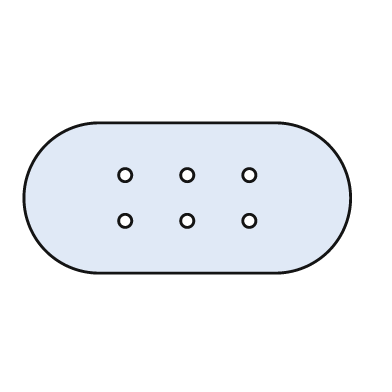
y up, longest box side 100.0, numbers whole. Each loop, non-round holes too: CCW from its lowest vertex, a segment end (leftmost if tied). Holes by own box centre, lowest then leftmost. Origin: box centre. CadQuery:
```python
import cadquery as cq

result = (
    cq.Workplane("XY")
    .moveTo(-27.0, -23.0)
    .lineTo(27.0, -23.0)
    .threePointArc((50.0, 0.0), (27.0, 23.0))
    .lineTo(-27.0, 23.0)
    .threePointArc((-50.0, 0.0), (-27.0, -23.0))
    .close()
    .moveTo(-19.0, -7.0)
    .circle(2.0)
    .moveTo(0.0, -7.0)
    .circle(2.0)
    .moveTo(19.0, -7.0)
    .circle(2.0)
    .moveTo(-19.0, 7.0)
    .circle(2.0)
    .moveTo(0.0, 7.0)
    .circle(2.0)
    .moveTo(19.0, 7.0)
    .circle(2.0)
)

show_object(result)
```